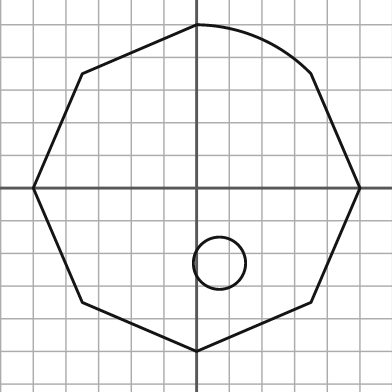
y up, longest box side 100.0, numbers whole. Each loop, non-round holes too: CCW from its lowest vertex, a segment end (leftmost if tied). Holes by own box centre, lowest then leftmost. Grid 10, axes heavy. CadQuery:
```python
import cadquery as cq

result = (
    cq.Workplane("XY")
    .moveTo(0.0, -50.0)
    .lineTo(35.0, -35.0)
    .lineTo(50.0, 0.0)
    .lineTo(35.0, 35.0)
    .threePointArc((19.0, 46.0), (0.0, 50.0))
    .lineTo(-35.0, 35.0)
    .lineTo(-50.0, 0.0)
    .lineTo(-35.0, -35.0)
    .close()
    .moveTo(7.0, -23.0)
    .circle(8.0)
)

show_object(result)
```